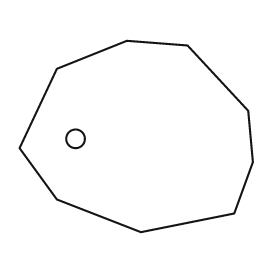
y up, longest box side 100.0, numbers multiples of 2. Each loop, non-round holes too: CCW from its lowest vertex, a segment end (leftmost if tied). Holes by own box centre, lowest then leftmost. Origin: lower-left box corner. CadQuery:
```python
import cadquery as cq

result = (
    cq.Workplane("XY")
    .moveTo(52.0, 0.0)
    .lineTo(92.0, 8.0)
    .lineTo(100.0, 30.0)
    .lineTo(98.0, 52.0)
    .lineTo(72.0, 80.0)
    .lineTo(46.0, 82.0)
    .lineTo(16.0, 70.0)
    .lineTo(0.0, 36.0)
    .lineTo(16.0, 14.0)
    .close()
    .moveTo(24.0, 40.0)
    .circle(4.0)
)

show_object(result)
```